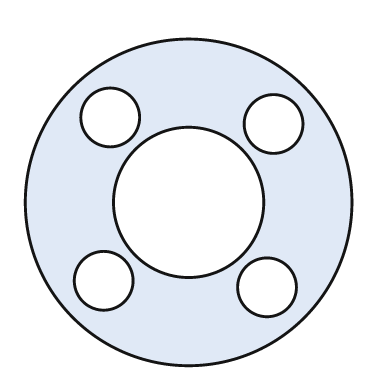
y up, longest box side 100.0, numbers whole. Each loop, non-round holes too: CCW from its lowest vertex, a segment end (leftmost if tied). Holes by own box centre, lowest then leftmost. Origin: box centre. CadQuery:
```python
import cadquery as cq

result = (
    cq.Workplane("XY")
    .moveTo(0.0, 0.0)
    .circle(50.0)
    .moveTo(24.0, -26.0)
    .circle(9.0)
    .moveTo(-26.0, -24.0)
    .circle(9.0)
    .moveTo(0.0, 0.0)
    .circle(23.0)
    .moveTo(26.0, 24.0)
    .circle(9.0)
    .moveTo(-24.0, 26.0)
    .circle(9.0)
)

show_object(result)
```